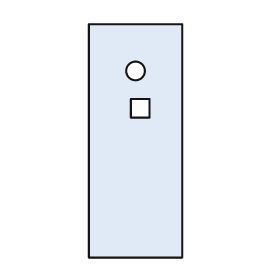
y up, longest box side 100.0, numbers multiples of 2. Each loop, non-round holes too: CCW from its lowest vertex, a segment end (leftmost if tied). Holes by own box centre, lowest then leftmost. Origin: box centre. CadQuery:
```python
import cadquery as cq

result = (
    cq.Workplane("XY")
    .moveTo(-20.0, -50.0)
    .lineTo(20.0, -50.0)
    .lineTo(20.0, 50.0)
    .lineTo(-20.0, 50.0)
    .close()
    .moveTo(-2.0, 10.0)
    .lineTo(6.0, 10.0)
    .lineTo(6.0, 18.0)
    .lineTo(-2.0, 18.0)
    .close()
    .moveTo(0.0, 30.0)
    .circle(4.0)
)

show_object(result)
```